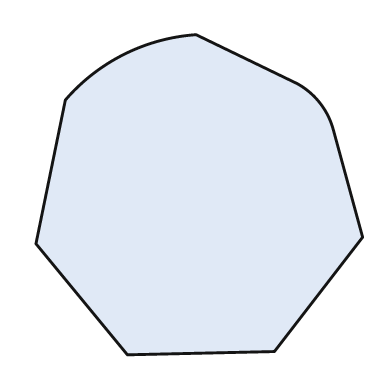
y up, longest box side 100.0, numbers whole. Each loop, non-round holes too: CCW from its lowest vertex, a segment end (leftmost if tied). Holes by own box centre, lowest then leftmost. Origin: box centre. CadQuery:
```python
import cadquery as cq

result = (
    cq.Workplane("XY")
    .moveTo(-22.0, -49.0)
    .lineTo(23.0, -48.0)
    .lineTo(50.0, -13.0)
    .lineTo(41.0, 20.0)
    .threePointArc((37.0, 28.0), (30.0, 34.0))
    .lineTo(-1.0, 49.0)
    .threePointArc((-23.0, 43.0), (-41.0, 29.0))
    .lineTo(-50.0, -15.0)
    .close()
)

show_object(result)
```